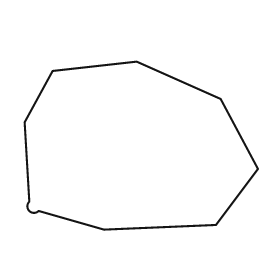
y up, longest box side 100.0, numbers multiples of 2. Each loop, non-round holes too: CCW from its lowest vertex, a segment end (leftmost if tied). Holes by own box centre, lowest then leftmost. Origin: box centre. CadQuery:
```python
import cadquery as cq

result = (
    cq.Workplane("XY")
    .moveTo(-16.0, -36.0)
    .lineTo(32.0, -34.0)
    .lineTo(50.0, -10.0)
    .lineTo(34.0, 20.0)
    .lineTo(-2.0, 36.0)
    .lineTo(-38.0, 32.0)
    .lineTo(-50.0, 10.0)
    .lineTo(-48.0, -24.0)
    .threePointArc((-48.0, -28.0), (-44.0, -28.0))
    .close()
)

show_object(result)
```